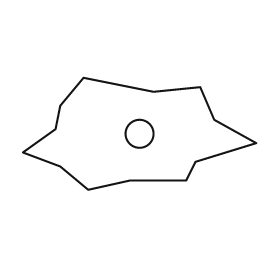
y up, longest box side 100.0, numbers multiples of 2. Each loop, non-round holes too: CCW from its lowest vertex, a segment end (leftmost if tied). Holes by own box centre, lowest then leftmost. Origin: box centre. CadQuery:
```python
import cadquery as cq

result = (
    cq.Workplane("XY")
    .moveTo(-22.0, -24.0)
    .lineTo(-4.0, -20.0)
    .lineTo(20.0, -20.0)
    .lineTo(24.0, -12.0)
    .lineTo(50.0, -4.0)
    .lineTo(32.0, 6.0)
    .lineTo(26.0, 20.0)
    .lineTo(6.0, 18.0)
    .lineTo(-24.0, 24.0)
    .lineTo(-34.0, 12.0)
    .lineTo(-36.0, 2.0)
    .lineTo(-50.0, -8.0)
    .lineTo(-34.0, -14.0)
    .close()
    .moveTo(0.0, 0.0)
    .circle(6.0)
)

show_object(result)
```